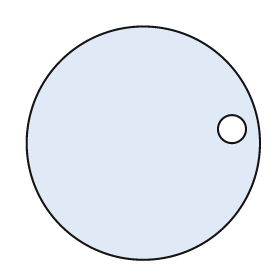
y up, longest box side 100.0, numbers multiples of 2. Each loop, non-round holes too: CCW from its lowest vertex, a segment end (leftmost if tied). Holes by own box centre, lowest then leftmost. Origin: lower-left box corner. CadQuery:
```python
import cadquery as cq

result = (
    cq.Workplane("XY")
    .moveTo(50.0, 50.0)
    .circle(50.0)
    .moveTo(88.0, 56.0)
    .circle(6.0)
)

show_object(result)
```